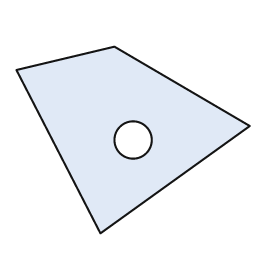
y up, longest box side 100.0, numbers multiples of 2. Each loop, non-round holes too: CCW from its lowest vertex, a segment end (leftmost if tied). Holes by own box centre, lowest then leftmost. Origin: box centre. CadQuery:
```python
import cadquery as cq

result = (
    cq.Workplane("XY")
    .moveTo(-14.0, -40.0)
    .lineTo(50.0, 6.0)
    .lineTo(-8.0, 40.0)
    .lineTo(-50.0, 30.0)
    .close()
    .moveTo(0.0, 0.0)
    .circle(8.0)
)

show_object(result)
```